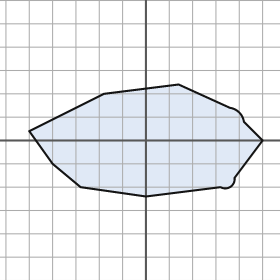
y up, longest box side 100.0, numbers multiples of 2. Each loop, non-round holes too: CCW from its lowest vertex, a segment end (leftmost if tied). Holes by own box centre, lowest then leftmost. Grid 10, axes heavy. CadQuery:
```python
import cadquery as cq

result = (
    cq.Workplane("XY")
    .moveTo(0.0, -24.0)
    .lineTo(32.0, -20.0)
    .threePointArc((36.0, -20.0), (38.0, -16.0))
    .lineTo(50.0, 0.0)
    .lineTo(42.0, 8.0)
    .threePointArc((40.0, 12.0), (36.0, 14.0))
    .lineTo(14.0, 24.0)
    .lineTo(-18.0, 20.0)
    .lineTo(-50.0, 4.0)
    .lineTo(-40.0, -10.0)
    .lineTo(-28.0, -20.0)
    .close()
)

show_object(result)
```